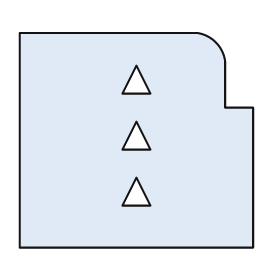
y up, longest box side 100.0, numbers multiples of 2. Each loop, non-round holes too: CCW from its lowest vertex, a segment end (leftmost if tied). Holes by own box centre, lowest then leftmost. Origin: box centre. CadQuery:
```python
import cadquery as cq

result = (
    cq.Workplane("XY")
    .moveTo(-50.0, -46.0)
    .lineTo(50.0, -46.0)
    .lineTo(50.0, 14.0)
    .lineTo(38.0, 14.0)
    .lineTo(38.0, 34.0)
    .threePointArc((34.0, 42.0), (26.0, 46.0))
    .lineTo(-50.0, 46.0)
    .close()
    .moveTo(-6.0, -28.0)
    .lineTo(6.0, -28.0)
    .lineTo(0.0, -16.0)
    .close()
    .moveTo(-6.0, -4.0)
    .lineTo(6.0, -4.0)
    .lineTo(0.0, 8.0)
    .close()
    .moveTo(-6.0, 20.0)
    .lineTo(6.0, 20.0)
    .lineTo(0.0, 32.0)
    .close()
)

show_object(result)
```